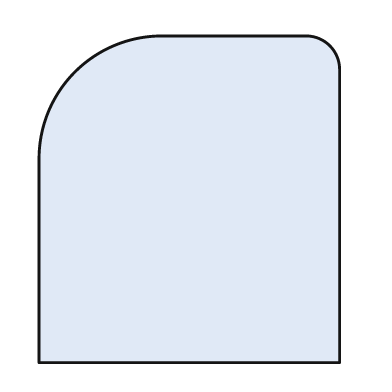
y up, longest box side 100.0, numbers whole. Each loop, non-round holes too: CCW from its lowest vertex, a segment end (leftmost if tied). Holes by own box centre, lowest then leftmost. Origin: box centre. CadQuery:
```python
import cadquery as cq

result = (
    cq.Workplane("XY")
    .moveTo(-46.0, -50.0)
    .lineTo(46.0, -50.0)
    .lineTo(46.0, 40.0)
    .threePointArc((43.0, 47.0), (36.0, 50.0))
    .lineTo(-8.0, 50.0)
    .threePointArc((-35.0, 39.0), (-46.0, 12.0))
    .close()
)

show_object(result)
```